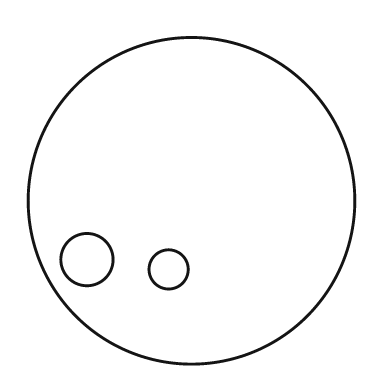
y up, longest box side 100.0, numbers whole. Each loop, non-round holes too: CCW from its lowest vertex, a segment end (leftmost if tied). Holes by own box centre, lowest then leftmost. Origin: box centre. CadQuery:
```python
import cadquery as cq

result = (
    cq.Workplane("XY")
    .moveTo(0.0, 0.0)
    .circle(50.0)
    .moveTo(-7.0, -21.0)
    .circle(6.0)
    .moveTo(-32.0, -18.0)
    .circle(8.0)
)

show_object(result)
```